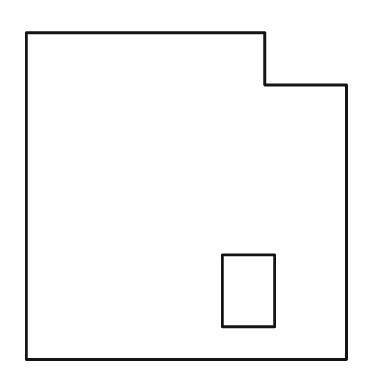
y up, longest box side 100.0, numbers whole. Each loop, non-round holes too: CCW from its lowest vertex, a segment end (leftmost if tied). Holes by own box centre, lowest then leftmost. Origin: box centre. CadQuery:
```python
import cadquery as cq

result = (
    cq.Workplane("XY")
    .moveTo(-49.0, -50.0)
    .lineTo(49.0, -50.0)
    .lineTo(49.0, 34.0)
    .lineTo(24.0, 34.0)
    .lineTo(24.0, 50.0)
    .lineTo(-49.0, 50.0)
    .close()
    .moveTo(11.0, -40.0)
    .lineTo(27.0, -40.0)
    .lineTo(27.0, -18.0)
    .lineTo(11.0, -18.0)
    .close()
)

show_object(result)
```